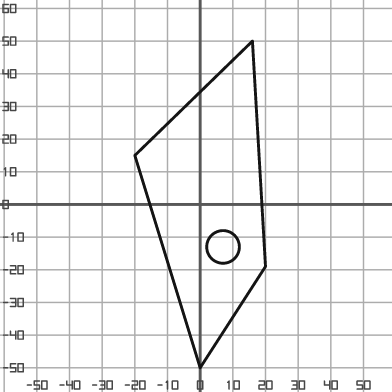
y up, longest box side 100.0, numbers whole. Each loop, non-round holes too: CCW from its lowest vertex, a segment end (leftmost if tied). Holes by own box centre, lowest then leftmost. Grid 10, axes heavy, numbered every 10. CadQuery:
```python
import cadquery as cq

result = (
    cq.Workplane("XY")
    .moveTo(0.0, -50.0)
    .lineTo(20.0, -19.0)
    .lineTo(16.0, 50.0)
    .lineTo(-20.0, 15.0)
    .close()
    .moveTo(7.0, -13.0)
    .circle(5.0)
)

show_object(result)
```